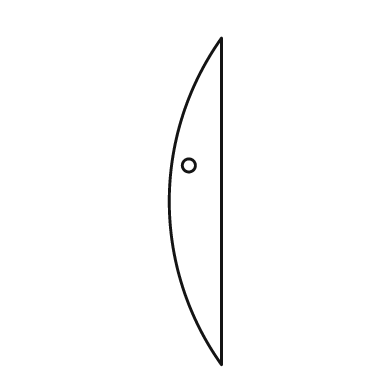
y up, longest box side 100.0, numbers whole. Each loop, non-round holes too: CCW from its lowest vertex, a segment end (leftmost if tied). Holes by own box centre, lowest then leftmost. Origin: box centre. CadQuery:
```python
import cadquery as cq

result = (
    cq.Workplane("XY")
    .moveTo(8.0, -50.0)
    .lineTo(8.0, 50.0)
    .threePointArc((-8.0, 0.0), (8.0, -50.0))
    .close()
    .moveTo(-2.0, 11.0)
    .circle(2.0)
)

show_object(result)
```